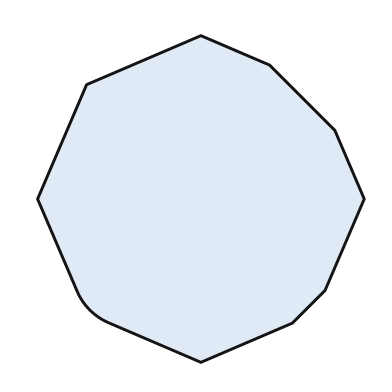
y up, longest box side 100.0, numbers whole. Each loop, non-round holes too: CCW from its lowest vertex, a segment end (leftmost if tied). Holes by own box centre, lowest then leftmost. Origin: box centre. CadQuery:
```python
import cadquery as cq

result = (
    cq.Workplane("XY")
    .moveTo(0.0, -50.0)
    .lineTo(28.0, -38.0)
    .lineTo(38.0, -28.0)
    .lineTo(50.0, 0.0)
    .lineTo(41.0, 21.0)
    .lineTo(21.0, 41.0)
    .lineTo(0.0, 50.0)
    .lineTo(-35.0, 35.0)
    .lineTo(-50.0, 0.0)
    .lineTo(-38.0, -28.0)
    .threePointArc((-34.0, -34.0), (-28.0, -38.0))
    .close()
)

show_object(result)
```